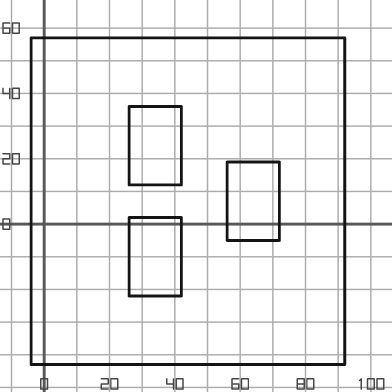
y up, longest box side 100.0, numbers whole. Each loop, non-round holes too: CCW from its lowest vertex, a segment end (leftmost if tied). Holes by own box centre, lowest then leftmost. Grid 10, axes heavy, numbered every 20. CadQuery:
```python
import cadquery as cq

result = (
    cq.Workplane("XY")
    .moveTo(-4.0, -43.0)
    .lineTo(92.0, -43.0)
    .lineTo(92.0, 57.0)
    .lineTo(-4.0, 57.0)
    .close()
    .moveTo(26.0, -22.0)
    .lineTo(42.0, -22.0)
    .lineTo(42.0, 2.0)
    .lineTo(26.0, 2.0)
    .close()
    .moveTo(56.0, -5.0)
    .lineTo(72.0, -5.0)
    .lineTo(72.0, 19.0)
    .lineTo(56.0, 19.0)
    .close()
    .moveTo(26.0, 12.0)
    .lineTo(42.0, 12.0)
    .lineTo(42.0, 36.0)
    .lineTo(26.0, 36.0)
    .close()
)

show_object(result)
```